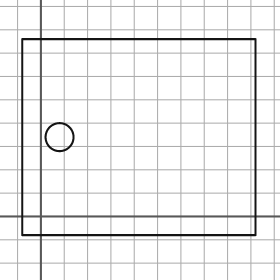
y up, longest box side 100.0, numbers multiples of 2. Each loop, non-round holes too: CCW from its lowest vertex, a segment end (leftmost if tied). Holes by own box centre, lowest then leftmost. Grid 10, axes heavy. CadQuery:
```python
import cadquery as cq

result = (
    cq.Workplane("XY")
    .moveTo(-8.0, -8.0)
    .lineTo(92.0, -8.0)
    .lineTo(92.0, 76.0)
    .lineTo(-8.0, 76.0)
    .close()
    .moveTo(8.0, 34.0)
    .circle(6.0)
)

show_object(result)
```